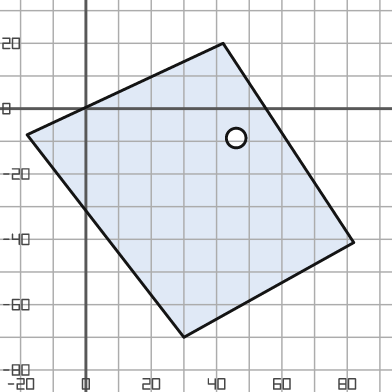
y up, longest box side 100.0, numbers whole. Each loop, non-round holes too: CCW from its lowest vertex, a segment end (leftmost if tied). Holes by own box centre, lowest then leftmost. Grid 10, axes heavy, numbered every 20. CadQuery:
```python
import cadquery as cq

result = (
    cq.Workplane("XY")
    .moveTo(30.0, -70.0)
    .lineTo(82.0, -41.0)
    .lineTo(42.0, 20.0)
    .lineTo(-18.0, -8.0)
    .close()
    .moveTo(46.0, -9.0)
    .circle(3.0)
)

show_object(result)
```